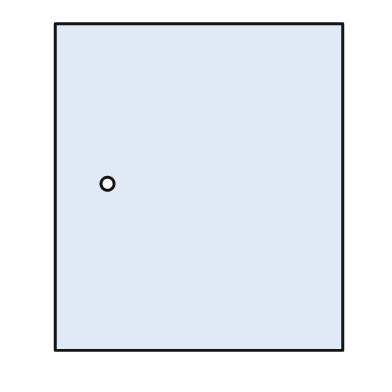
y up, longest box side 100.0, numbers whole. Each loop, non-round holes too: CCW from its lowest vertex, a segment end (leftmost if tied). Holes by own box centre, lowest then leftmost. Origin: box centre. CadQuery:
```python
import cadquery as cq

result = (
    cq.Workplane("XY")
    .moveTo(-44.0, -50.0)
    .lineTo(44.0, -50.0)
    .lineTo(44.0, 50.0)
    .lineTo(-44.0, 50.0)
    .close()
    .moveTo(-28.0, 1.0)
    .circle(2.0)
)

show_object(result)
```